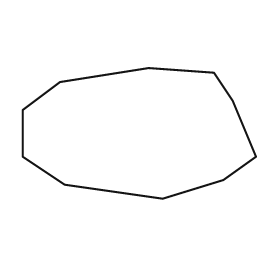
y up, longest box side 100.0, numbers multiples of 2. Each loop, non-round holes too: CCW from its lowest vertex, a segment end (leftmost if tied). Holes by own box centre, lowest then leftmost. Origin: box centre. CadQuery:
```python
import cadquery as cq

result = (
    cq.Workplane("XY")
    .moveTo(10.0, -28.0)
    .lineTo(36.0, -20.0)
    .lineTo(50.0, -10.0)
    .lineTo(40.0, 14.0)
    .lineTo(32.0, 26.0)
    .lineTo(4.0, 28.0)
    .lineTo(-34.0, 22.0)
    .lineTo(-50.0, 10.0)
    .lineTo(-50.0, -10.0)
    .lineTo(-32.0, -22.0)
    .close()
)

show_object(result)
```